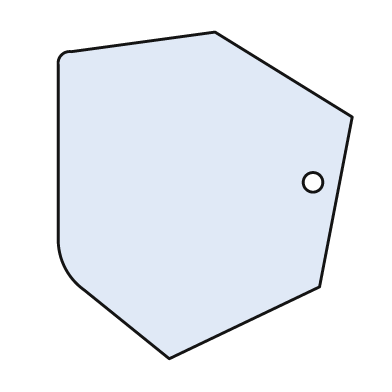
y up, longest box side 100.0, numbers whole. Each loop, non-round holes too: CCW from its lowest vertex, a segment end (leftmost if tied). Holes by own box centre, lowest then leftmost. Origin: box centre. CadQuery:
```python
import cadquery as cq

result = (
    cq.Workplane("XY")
    .moveTo(-11.0, -50.0)
    .lineTo(35.0, -28.0)
    .lineTo(45.0, 24.0)
    .lineTo(3.0, 50.0)
    .lineTo(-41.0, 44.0)
    .threePointArc((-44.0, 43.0), (-45.0, 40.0))
    .lineTo(-45.0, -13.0)
    .threePointArc((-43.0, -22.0), (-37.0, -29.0))
    .close()
    .moveTo(33.0, 4.0)
    .circle(3.0)
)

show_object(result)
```